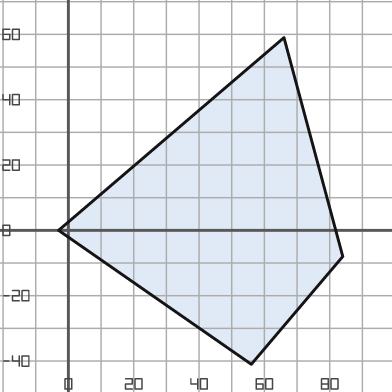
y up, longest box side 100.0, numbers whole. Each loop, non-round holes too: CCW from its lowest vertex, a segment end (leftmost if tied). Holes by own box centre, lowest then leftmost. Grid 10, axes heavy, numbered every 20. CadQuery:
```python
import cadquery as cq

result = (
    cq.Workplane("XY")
    .moveTo(56.0, -41.0)
    .lineTo(84.0, -8.0)
    .lineTo(66.0, 59.0)
    .lineTo(-3.0, 0.0)
    .close()
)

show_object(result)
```